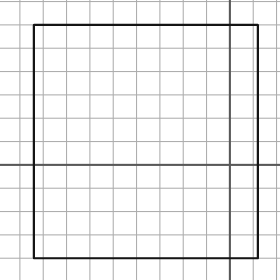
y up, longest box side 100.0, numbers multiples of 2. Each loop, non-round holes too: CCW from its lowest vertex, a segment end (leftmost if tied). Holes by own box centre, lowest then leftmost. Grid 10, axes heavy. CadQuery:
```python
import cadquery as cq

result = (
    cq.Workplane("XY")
    .moveTo(-84.0, -40.0)
    .lineTo(12.0, -40.0)
    .lineTo(12.0, 60.0)
    .lineTo(-84.0, 60.0)
    .close()
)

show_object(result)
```